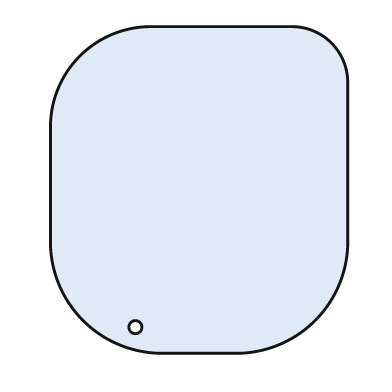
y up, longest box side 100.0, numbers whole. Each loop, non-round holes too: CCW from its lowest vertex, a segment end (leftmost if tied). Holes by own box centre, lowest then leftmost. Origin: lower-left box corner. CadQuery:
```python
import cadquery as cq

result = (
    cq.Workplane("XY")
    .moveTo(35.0, 0.0)
    .lineTo(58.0, 0.0)
    .threePointArc((81.0, 10.0), (91.0, 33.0))
    .lineTo(91.0, 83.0)
    .threePointArc((86.0, 95.0), (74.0, 100.0))
    .lineTo(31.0, 100.0)
    .threePointArc((9.0, 91.0), (0.0, 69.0))
    .lineTo(0.0, 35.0)
    .threePointArc((10.0, 10.0), (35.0, 0.0))
    .close()
    .moveTo(26.0, 8.0)
    .circle(2.0)
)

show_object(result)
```